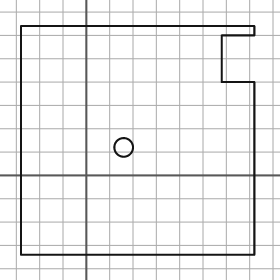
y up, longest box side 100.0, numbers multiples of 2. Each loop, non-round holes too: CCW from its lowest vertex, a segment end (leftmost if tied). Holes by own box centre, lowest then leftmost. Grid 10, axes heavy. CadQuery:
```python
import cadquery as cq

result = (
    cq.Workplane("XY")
    .moveTo(-28.0, -34.0)
    .lineTo(72.0, -34.0)
    .lineTo(72.0, 40.0)
    .lineTo(58.0, 40.0)
    .lineTo(58.0, 60.0)
    .lineTo(72.0, 60.0)
    .lineTo(72.0, 64.0)
    .lineTo(-28.0, 64.0)
    .close()
    .moveTo(16.0, 12.0)
    .circle(4.0)
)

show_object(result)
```